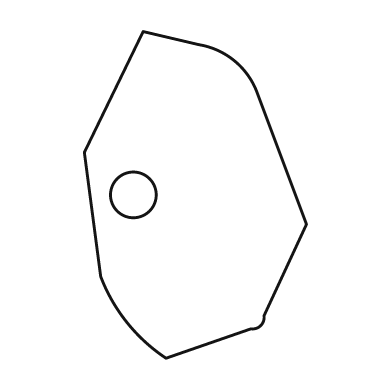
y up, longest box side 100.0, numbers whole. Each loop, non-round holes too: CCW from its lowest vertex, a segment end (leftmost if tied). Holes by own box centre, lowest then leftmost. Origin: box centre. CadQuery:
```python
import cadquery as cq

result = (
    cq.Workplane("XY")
    .moveTo(-9.0, -50.0)
    .lineTo(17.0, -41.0)
    .threePointArc((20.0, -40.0), (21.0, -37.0))
    .lineTo(34.0, -9.0)
    .lineTo(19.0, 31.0)
    .threePointArc((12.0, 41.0), (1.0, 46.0))
    .lineTo(-16.0, 50.0)
    .lineTo(-34.0, 13.0)
    .lineTo(-29.0, -25.0)
    .threePointArc((-21.0, -39.0), (-9.0, -50.0))
    .close()
    .moveTo(-19.0, 0.0)
    .circle(7.0)
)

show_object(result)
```